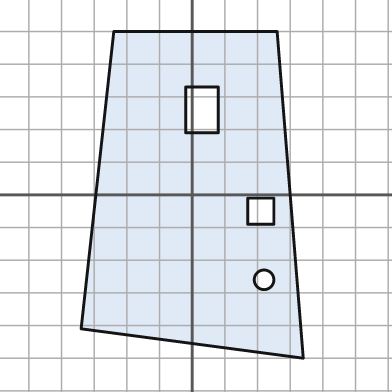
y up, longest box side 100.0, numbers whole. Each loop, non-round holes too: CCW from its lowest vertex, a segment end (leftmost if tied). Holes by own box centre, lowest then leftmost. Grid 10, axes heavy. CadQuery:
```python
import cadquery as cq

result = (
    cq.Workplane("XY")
    .moveTo(34.0, -50.0)
    .lineTo(26.0, 50.0)
    .lineTo(-24.0, 50.0)
    .lineTo(-34.0, -41.0)
    .close()
    .moveTo(22.0, -26.0)
    .circle(3.0)
    .moveTo(17.0, -9.0)
    .lineTo(25.0, -9.0)
    .lineTo(25.0, -1.0)
    .lineTo(17.0, -1.0)
    .close()
    .moveTo(-2.0, 19.0)
    .lineTo(8.0, 19.0)
    .lineTo(8.0, 33.0)
    .lineTo(-2.0, 33.0)
    .close()
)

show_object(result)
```